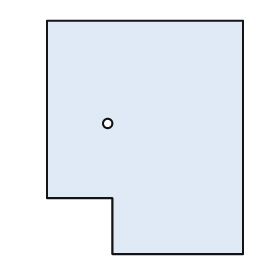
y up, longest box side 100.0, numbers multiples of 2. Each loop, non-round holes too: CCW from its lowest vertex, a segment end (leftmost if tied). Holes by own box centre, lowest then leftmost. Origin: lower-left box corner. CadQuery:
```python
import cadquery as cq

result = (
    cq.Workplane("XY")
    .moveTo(28.0, 0.0)
    .lineTo(84.0, 0.0)
    .lineTo(84.0, 100.0)
    .lineTo(0.0, 100.0)
    .lineTo(0.0, 24.0)
    .lineTo(28.0, 24.0)
    .close()
    .moveTo(26.0, 56.0)
    .circle(2.0)
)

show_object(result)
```